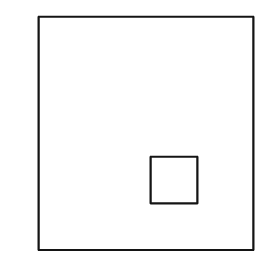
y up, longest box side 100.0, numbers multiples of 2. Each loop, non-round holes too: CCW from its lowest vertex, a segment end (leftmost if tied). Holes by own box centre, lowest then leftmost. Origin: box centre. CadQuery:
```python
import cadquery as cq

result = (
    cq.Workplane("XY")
    .moveTo(-46.0, -50.0)
    .lineTo(46.0, -50.0)
    .lineTo(46.0, 50.0)
    .lineTo(-46.0, 50.0)
    .close()
    .moveTo(2.0, -30.0)
    .lineTo(22.0, -30.0)
    .lineTo(22.0, -10.0)
    .lineTo(2.0, -10.0)
    .close()
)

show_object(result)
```